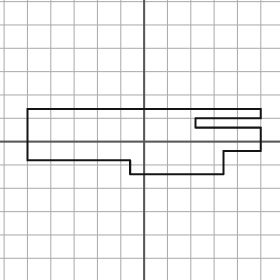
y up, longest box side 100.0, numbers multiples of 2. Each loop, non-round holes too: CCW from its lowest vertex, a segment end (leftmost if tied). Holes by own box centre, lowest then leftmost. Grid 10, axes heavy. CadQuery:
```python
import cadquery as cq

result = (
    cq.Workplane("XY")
    .moveTo(-6.0, -14.0)
    .lineTo(34.0, -14.0)
    .lineTo(34.0, -4.0)
    .lineTo(50.0, -4.0)
    .lineTo(50.0, 6.0)
    .lineTo(22.0, 6.0)
    .lineTo(22.0, 10.0)
    .lineTo(50.0, 10.0)
    .lineTo(50.0, 14.0)
    .lineTo(-50.0, 14.0)
    .lineTo(-50.0, -8.0)
    .lineTo(-6.0, -8.0)
    .close()
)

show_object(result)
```